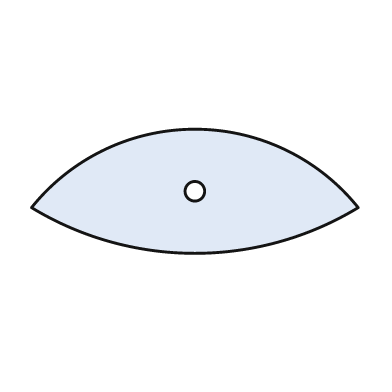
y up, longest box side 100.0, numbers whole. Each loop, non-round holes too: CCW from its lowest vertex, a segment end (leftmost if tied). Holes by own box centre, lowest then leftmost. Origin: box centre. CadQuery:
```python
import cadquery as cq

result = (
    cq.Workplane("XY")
    .moveTo(-50.0, -5.0)
    .threePointArc((0.0, -19.0), (50.0, -5.0))
    .threePointArc((0.0, 19.0), (-50.0, -5.0))
    .close()
    .moveTo(0.0, 0.0)
    .circle(3.0)
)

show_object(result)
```